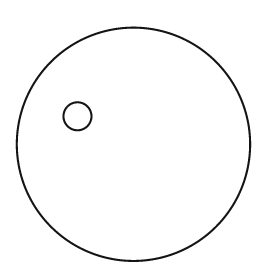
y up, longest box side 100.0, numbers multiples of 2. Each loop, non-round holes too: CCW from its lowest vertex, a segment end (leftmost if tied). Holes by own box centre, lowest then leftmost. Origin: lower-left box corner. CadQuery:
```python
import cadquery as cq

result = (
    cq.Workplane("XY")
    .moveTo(50.0, 50.0)
    .circle(50.0)
    .moveTo(26.0, 62.0)
    .circle(6.0)
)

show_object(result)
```